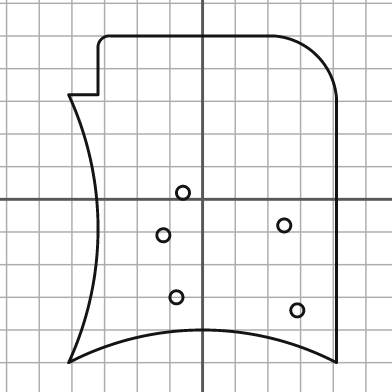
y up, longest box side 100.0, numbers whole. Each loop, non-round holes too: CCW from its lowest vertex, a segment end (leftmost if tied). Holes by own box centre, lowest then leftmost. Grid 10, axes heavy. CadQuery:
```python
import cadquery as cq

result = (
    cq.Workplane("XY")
    .moveTo(-41.0, -50.0)
    .threePointArc((0.0, -40.0), (41.0, -50.0))
    .lineTo(41.0, 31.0)
    .threePointArc((35.0, 44.0), (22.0, 50.0))
    .lineTo(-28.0, 50.0)
    .threePointArc((-31.0, 49.0), (-32.0, 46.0))
    .lineTo(-32.0, 32.0)
    .lineTo(-41.0, 32.0)
    .threePointArc((-32.0, -9.0), (-41.0, -50.0))
    .close()
    .moveTo(29.0, -34.0)
    .circle(2.0)
    .moveTo(-8.0, -30.0)
    .circle(2.0)
    .moveTo(-12.0, -11.0)
    .circle(2.0)
    .moveTo(25.0, -8.0)
    .circle(2.0)
    .moveTo(-6.0, 2.0)
    .circle(2.0)
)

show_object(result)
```